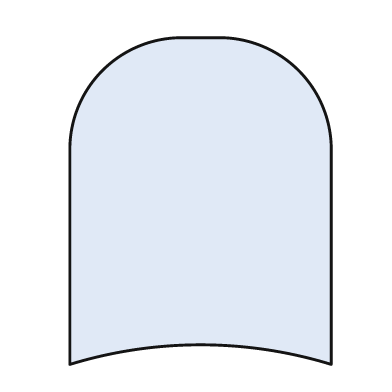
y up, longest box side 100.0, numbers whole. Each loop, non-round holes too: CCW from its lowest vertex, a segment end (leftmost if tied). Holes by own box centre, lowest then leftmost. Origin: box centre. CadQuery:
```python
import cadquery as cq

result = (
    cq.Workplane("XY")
    .moveTo(-40.0, -50.0)
    .threePointArc((0.0, -44.0), (40.0, -50.0))
    .lineTo(40.0, 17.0)
    .threePointArc((30.0, 40.0), (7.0, 50.0))
    .lineTo(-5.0, 50.0)
    .threePointArc((-30.0, 40.0), (-40.0, 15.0))
    .close()
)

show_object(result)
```